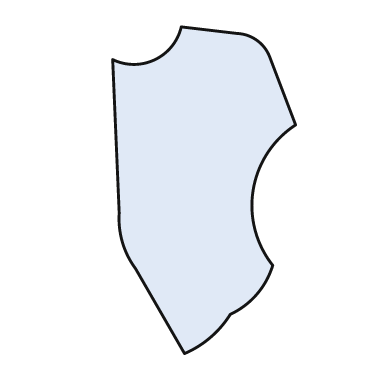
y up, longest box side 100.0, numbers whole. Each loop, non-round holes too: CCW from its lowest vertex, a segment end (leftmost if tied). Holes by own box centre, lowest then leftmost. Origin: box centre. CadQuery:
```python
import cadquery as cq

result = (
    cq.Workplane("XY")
    .moveTo(-6.0, -50.0)
    .threePointArc((2.0, -45.0), (8.0, -38.0))
    .threePointArc((16.0, -32.0), (21.0, -23.0))
    .threePointArc((15.0, 0.0), (28.0, 20.0))
    .lineTo(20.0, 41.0)
    .threePointArc((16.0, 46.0), (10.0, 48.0))
    .lineTo(-7.0, 50.0)
    .threePointArc((-15.0, 40.0), (-28.0, 40.0))
    .lineTo(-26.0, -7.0)
    .threePointArc((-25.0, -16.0), (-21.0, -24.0))
    .close()
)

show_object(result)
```